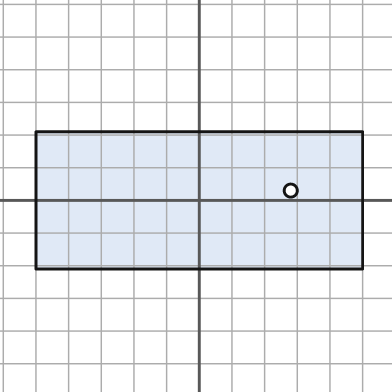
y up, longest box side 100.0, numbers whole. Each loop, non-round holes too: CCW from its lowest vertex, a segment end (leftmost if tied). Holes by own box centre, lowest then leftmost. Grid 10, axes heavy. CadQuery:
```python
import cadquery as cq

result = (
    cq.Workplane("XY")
    .moveTo(-50.0, -21.0)
    .lineTo(50.0, -21.0)
    .lineTo(50.0, 21.0)
    .lineTo(-50.0, 21.0)
    .close()
    .moveTo(28.0, 3.0)
    .circle(2.0)
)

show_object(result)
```